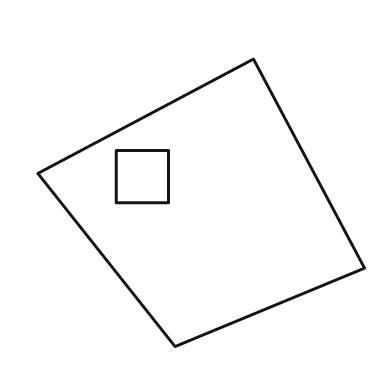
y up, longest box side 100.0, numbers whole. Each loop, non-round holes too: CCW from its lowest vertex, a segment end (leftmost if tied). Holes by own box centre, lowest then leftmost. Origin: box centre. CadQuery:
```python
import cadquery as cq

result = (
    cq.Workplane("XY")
    .moveTo(-8.0, -44.0)
    .lineTo(50.0, -20.0)
    .lineTo(16.0, 44.0)
    .lineTo(-50.0, 9.0)
    .close()
    .moveTo(-26.0, 0.0)
    .lineTo(-10.0, 0.0)
    .lineTo(-10.0, 16.0)
    .lineTo(-26.0, 16.0)
    .close()
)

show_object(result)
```